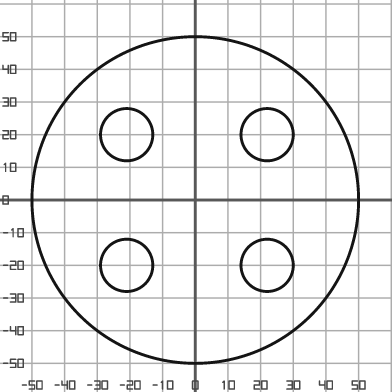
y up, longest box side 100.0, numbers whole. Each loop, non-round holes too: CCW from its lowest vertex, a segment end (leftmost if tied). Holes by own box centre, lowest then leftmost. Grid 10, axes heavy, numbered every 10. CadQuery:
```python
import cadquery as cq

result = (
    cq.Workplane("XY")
    .moveTo(0.0, 0.0)
    .circle(50.0)
    .moveTo(-21.0, -20.0)
    .circle(8.0)
    .moveTo(22.0, -20.0)
    .circle(8.0)
    .moveTo(-21.0, 20.0)
    .circle(8.0)
    .moveTo(22.0, 20.0)
    .circle(8.0)
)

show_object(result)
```